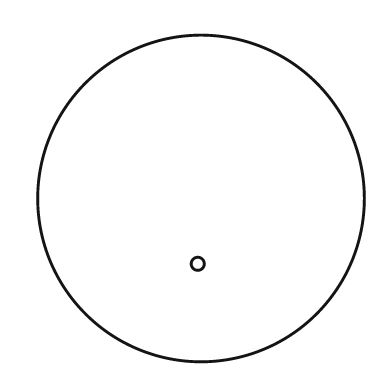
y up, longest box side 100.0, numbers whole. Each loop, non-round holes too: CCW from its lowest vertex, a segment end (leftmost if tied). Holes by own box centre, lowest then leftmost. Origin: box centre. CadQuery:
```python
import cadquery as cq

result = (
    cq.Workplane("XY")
    .moveTo(0.0, 0.0)
    .circle(50.0)
    .moveTo(-1.0, -20.0)
    .circle(2.0)
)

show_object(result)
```